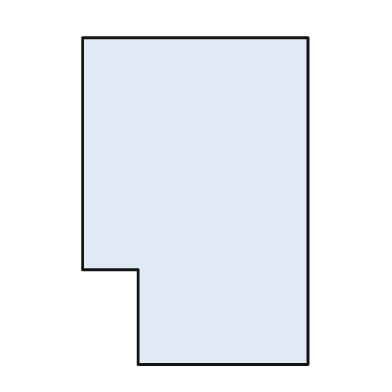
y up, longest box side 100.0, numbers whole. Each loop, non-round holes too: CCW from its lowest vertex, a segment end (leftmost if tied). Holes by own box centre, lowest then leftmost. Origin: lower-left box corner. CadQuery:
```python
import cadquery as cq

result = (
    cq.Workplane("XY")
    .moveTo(17.0, 0.0)
    .lineTo(69.0, 0.0)
    .lineTo(69.0, 100.0)
    .lineTo(0.0, 100.0)
    .lineTo(0.0, 29.0)
    .lineTo(17.0, 29.0)
    .close()
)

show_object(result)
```